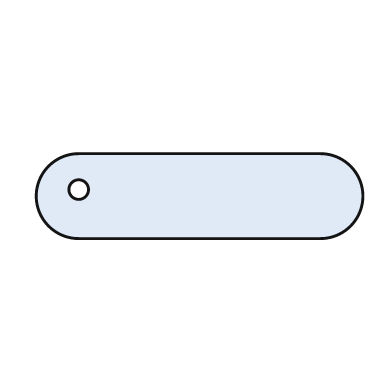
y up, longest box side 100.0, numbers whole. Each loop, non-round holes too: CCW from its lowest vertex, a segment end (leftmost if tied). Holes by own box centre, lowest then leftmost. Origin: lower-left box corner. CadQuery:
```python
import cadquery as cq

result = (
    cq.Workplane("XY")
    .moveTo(13.0, 0.0)
    .lineTo(87.0, 0.0)
    .threePointArc((100.0, 13.0), (87.0, 26.0))
    .lineTo(13.0, 26.0)
    .threePointArc((0.0, 13.0), (13.0, 0.0))
    .close()
    .moveTo(13.0, 15.0)
    .circle(3.0)
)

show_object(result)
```